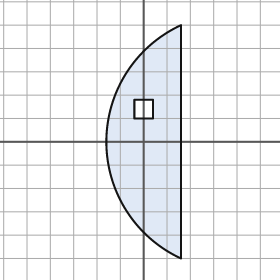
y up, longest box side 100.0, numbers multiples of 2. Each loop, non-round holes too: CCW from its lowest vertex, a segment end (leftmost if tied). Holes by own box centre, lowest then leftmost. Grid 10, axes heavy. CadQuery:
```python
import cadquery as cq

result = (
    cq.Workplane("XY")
    .moveTo(16.0, -50.0)
    .lineTo(16.0, 50.0)
    .threePointArc((-16.0, 0.0), (16.0, -50.0))
    .close()
    .moveTo(-4.0, 10.0)
    .lineTo(4.0, 10.0)
    .lineTo(4.0, 18.0)
    .lineTo(-4.0, 18.0)
    .close()
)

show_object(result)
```